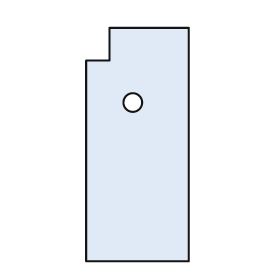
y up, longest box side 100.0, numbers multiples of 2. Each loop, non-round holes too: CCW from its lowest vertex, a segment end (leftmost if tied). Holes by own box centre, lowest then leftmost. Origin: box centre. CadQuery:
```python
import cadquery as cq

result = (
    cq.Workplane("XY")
    .moveTo(-22.0, -50.0)
    .lineTo(22.0, -50.0)
    .lineTo(22.0, 50.0)
    .lineTo(-12.0, 50.0)
    .lineTo(-12.0, 36.0)
    .lineTo(-22.0, 36.0)
    .close()
    .moveTo(-2.0, 18.0)
    .circle(4.0)
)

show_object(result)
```